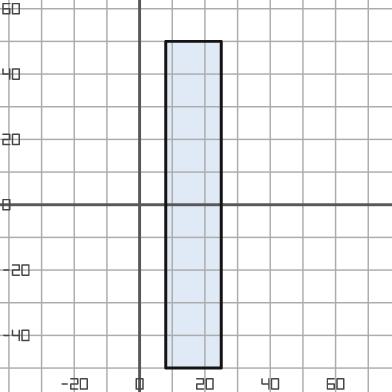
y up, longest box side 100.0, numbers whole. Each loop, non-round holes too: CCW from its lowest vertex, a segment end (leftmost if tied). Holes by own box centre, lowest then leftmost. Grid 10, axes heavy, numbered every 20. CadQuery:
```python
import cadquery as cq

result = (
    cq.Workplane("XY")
    .moveTo(8.0, -50.0)
    .lineTo(25.0, -50.0)
    .lineTo(25.0, 50.0)
    .lineTo(8.0, 50.0)
    .close()
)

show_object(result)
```